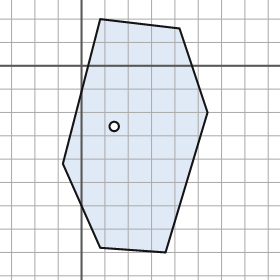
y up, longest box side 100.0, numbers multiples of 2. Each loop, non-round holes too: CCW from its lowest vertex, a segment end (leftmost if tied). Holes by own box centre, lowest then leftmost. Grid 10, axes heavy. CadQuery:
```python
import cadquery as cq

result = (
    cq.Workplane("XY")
    .moveTo(36.0, -80.0)
    .lineTo(54.0, -20.0)
    .lineTo(42.0, 16.0)
    .lineTo(8.0, 20.0)
    .lineTo(-8.0, -42.0)
    .lineTo(8.0, -78.0)
    .close()
    .moveTo(14.0, -26.0)
    .circle(2.0)
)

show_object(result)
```